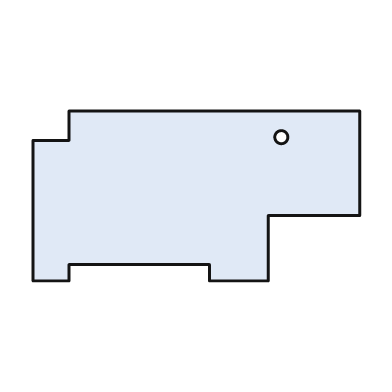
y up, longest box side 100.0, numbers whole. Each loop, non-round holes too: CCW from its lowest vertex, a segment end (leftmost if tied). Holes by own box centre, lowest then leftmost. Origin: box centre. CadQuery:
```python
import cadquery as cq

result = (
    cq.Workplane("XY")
    .moveTo(-50.0, -26.0)
    .lineTo(-39.0, -26.0)
    .lineTo(-39.0, -21.0)
    .lineTo(4.0, -21.0)
    .lineTo(4.0, -26.0)
    .lineTo(22.0, -26.0)
    .lineTo(22.0, -6.0)
    .lineTo(50.0, -6.0)
    .lineTo(50.0, 26.0)
    .lineTo(-39.0, 26.0)
    .lineTo(-39.0, 17.0)
    .lineTo(-50.0, 17.0)
    .close()
    .moveTo(26.0, 18.0)
    .circle(2.0)
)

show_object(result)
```